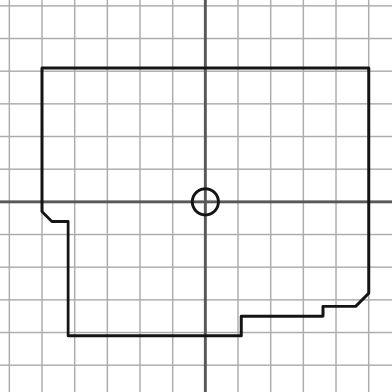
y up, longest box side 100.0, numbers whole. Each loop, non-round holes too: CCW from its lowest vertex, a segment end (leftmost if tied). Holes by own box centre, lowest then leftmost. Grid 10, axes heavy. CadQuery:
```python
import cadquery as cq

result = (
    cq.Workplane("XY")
    .moveTo(-42.0, -41.0)
    .lineTo(11.0, -41.0)
    .lineTo(11.0, -35.0)
    .lineTo(36.0, -35.0)
    .lineTo(36.0, -32.0)
    .lineTo(46.0, -32.0)
    .lineTo(50.0, -28.0)
    .lineTo(50.0, 41.0)
    .lineTo(-50.0, 41.0)
    .lineTo(-50.0, -3.0)
    .lineTo(-47.0, -6.0)
    .lineTo(-42.0, -6.0)
    .close()
    .moveTo(0.0, 0.0)
    .circle(4.0)
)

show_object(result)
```